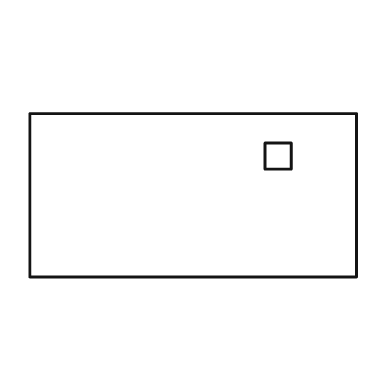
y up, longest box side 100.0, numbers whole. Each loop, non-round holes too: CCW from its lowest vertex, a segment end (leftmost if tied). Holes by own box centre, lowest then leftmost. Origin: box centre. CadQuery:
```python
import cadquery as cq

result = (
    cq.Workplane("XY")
    .moveTo(-50.0, -25.0)
    .lineTo(50.0, -25.0)
    .lineTo(50.0, 25.0)
    .lineTo(-50.0, 25.0)
    .close()
    .moveTo(22.0, 8.0)
    .lineTo(30.0, 8.0)
    .lineTo(30.0, 16.0)
    .lineTo(22.0, 16.0)
    .close()
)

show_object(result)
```